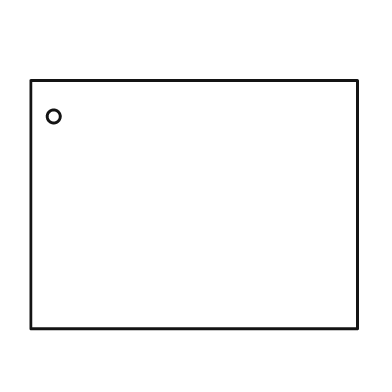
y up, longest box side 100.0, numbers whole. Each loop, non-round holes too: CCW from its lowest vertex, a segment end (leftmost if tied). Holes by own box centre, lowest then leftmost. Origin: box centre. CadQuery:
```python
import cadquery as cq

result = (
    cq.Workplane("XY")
    .moveTo(-50.0, -38.0)
    .lineTo(50.0, -38.0)
    .lineTo(50.0, 38.0)
    .lineTo(-50.0, 38.0)
    .close()
    .moveTo(-43.0, 27.0)
    .circle(2.0)
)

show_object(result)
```